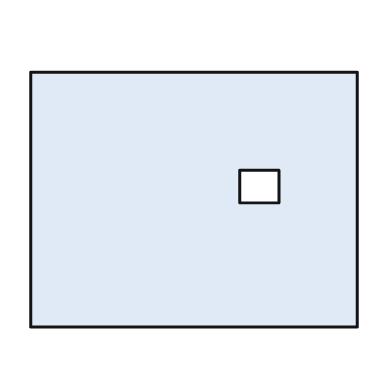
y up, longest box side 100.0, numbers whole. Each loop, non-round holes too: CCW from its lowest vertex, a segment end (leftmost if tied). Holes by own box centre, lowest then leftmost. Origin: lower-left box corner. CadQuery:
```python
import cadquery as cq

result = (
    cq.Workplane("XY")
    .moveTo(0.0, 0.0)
    .lineTo(100.0, 0.0)
    .lineTo(100.0, 78.0)
    .lineTo(0.0, 78.0)
    .close()
    .moveTo(64.0, 38.0)
    .lineTo(76.0, 38.0)
    .lineTo(76.0, 48.0)
    .lineTo(64.0, 48.0)
    .close()
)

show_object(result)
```